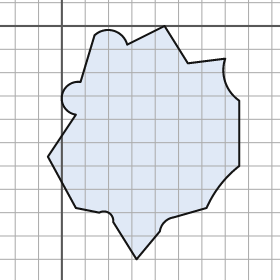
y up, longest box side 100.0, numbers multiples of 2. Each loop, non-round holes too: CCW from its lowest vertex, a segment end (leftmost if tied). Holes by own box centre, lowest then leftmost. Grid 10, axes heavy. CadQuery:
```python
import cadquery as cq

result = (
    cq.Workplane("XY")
    .moveTo(32.0, -100.0)
    .lineTo(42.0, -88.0)
    .threePointArc((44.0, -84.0), (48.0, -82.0))
    .lineTo(62.0, -78.0)
    .threePointArc((68.0, -68.0), (76.0, -60.0))
    .lineTo(76.0, -32.0)
    .threePointArc((70.0, -24.0), (70.0, -14.0))
    .lineTo(54.0, -16.0)
    .lineTo(44.0, 0.0)
    .lineTo(28.0, -8.0)
    .threePointArc((22.0, -2.0), (14.0, -4.0))
    .lineTo(8.0, -24.0)
    .threePointArc((0.0, -30.0), (6.0, -38.0))
    .lineTo(-6.0, -56.0)
    .lineTo(6.0, -78.0)
    .lineTo(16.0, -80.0)
    .threePointArc((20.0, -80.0), (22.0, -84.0))
    .close()
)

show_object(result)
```